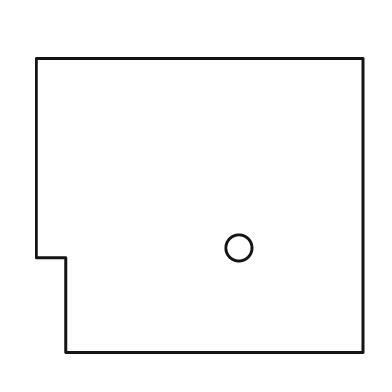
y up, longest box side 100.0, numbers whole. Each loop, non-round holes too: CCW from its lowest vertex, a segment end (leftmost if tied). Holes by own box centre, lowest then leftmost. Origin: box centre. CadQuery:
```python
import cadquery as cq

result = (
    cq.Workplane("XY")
    .moveTo(-41.0, -45.0)
    .lineTo(50.0, -45.0)
    .lineTo(50.0, 45.0)
    .lineTo(-50.0, 45.0)
    .lineTo(-50.0, -16.0)
    .lineTo(-41.0, -16.0)
    .close()
    .moveTo(12.0, -13.0)
    .circle(4.0)
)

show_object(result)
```